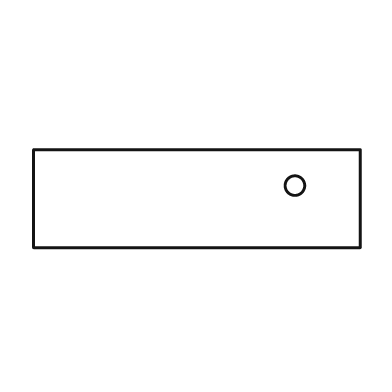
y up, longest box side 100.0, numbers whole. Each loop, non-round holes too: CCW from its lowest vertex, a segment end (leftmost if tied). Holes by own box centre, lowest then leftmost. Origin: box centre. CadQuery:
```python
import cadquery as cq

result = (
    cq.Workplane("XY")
    .moveTo(-50.0, -15.0)
    .lineTo(50.0, -15.0)
    .lineTo(50.0, 15.0)
    .lineTo(-50.0, 15.0)
    .close()
    .moveTo(30.0, 4.0)
    .circle(3.0)
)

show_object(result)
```